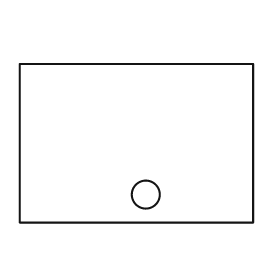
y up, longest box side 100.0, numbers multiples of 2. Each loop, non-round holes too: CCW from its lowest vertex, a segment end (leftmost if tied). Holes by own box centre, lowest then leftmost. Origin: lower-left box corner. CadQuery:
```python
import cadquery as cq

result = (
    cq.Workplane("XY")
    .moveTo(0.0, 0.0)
    .lineTo(100.0, 0.0)
    .lineTo(100.0, 68.0)
    .lineTo(0.0, 68.0)
    .close()
    .moveTo(54.0, 12.0)
    .circle(6.0)
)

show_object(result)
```